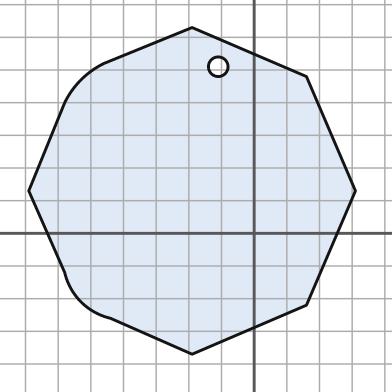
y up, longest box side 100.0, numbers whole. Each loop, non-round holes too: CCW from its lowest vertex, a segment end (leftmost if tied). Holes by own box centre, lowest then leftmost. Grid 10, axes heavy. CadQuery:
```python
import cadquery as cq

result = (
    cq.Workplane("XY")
    .moveTo(-19.0, -37.0)
    .lineTo(16.0, -22.0)
    .lineTo(31.0, 13.0)
    .lineTo(16.0, 48.0)
    .lineTo(-19.0, 63.0)
    .lineTo(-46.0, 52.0)
    .threePointArc((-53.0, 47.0), (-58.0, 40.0))
    .lineTo(-69.0, 13.0)
    .lineTo(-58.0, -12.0)
    .threePointArc((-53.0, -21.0), (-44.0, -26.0))
    .close()
    .moveTo(-11.0, 51.0)
    .circle(3.0)
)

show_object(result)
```